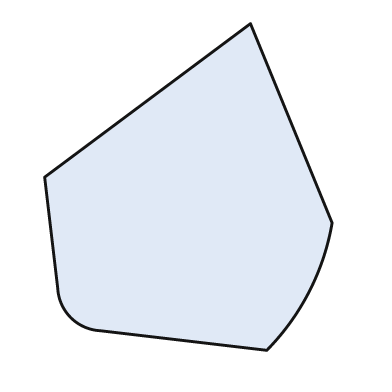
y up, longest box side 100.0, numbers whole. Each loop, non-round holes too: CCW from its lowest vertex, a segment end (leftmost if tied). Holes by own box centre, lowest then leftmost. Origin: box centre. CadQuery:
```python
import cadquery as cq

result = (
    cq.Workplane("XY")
    .moveTo(24.0, -50.0)
    .threePointArc((37.0, -32.0), (44.0, -11.0))
    .lineTo(19.0, 50.0)
    .lineTo(-44.0, 3.0)
    .lineTo(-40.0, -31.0)
    .threePointArc((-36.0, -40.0), (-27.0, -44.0))
    .close()
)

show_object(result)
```